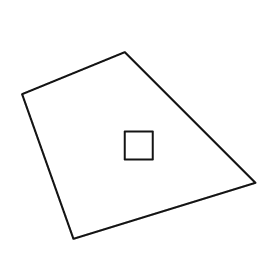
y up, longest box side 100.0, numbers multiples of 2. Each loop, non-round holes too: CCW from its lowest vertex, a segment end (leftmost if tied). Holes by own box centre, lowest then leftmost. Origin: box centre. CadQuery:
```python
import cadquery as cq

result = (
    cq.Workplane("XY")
    .moveTo(-28.0, -40.0)
    .lineTo(50.0, -16.0)
    .lineTo(-6.0, 40.0)
    .lineTo(-50.0, 22.0)
    .close()
    .moveTo(-6.0, -6.0)
    .lineTo(6.0, -6.0)
    .lineTo(6.0, 6.0)
    .lineTo(-6.0, 6.0)
    .close()
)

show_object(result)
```